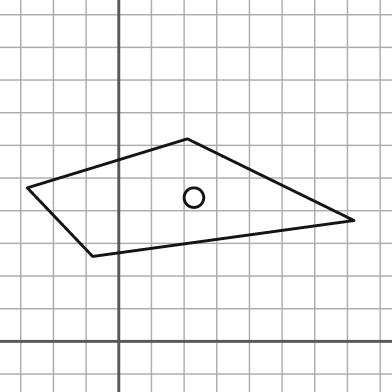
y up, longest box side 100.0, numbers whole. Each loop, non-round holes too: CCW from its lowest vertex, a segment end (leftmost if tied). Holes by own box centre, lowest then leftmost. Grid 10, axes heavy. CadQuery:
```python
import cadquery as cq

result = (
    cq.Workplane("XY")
    .moveTo(-8.0, 26.0)
    .lineTo(72.0, 37.0)
    .lineTo(21.0, 62.0)
    .lineTo(-28.0, 47.0)
    .close()
    .moveTo(23.0, 44.0)
    .circle(3.0)
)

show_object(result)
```